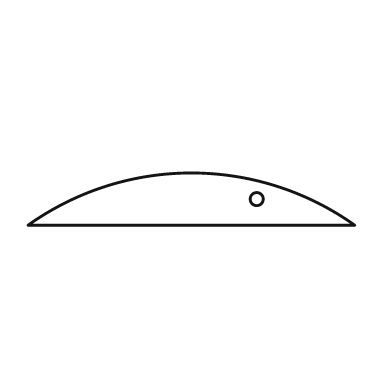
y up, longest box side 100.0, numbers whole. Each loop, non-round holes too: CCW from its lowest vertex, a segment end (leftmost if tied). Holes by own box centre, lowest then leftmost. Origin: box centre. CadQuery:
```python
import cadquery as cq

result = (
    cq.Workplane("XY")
    .moveTo(-50.0, -8.0)
    .lineTo(50.0, -8.0)
    .threePointArc((0.0, 8.0), (-50.0, -8.0))
    .close()
    .moveTo(20.0, 0.0)
    .circle(2.0)
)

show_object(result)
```